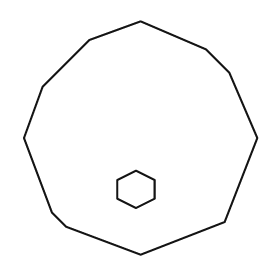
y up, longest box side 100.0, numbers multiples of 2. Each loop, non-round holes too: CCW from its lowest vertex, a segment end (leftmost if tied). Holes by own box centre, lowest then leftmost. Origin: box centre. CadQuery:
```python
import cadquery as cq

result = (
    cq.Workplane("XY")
    .moveTo(0.0, -50.0)
    .lineTo(36.0, -36.0)
    .lineTo(50.0, 0.0)
    .lineTo(38.0, 28.0)
    .lineTo(28.0, 38.0)
    .lineTo(0.0, 50.0)
    .lineTo(-22.0, 42.0)
    .lineTo(-42.0, 22.0)
    .lineTo(-50.0, 0.0)
    .lineTo(-38.0, -32.0)
    .lineTo(-32.0, -38.0)
    .close()
    .moveTo(-2.0, -30.0)
    .lineTo(6.0, -26.0)
    .lineTo(6.0, -18.0)
    .lineTo(-2.0, -14.0)
    .lineTo(-10.0, -18.0)
    .lineTo(-10.0, -26.0)
    .close()
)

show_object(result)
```